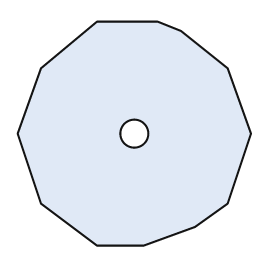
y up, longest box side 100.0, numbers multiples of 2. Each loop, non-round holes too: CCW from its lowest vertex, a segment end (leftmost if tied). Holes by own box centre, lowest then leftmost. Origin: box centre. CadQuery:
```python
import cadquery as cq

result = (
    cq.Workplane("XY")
    .moveTo(-16.0, -48.0)
    .lineTo(4.0, -48.0)
    .lineTo(26.0, -40.0)
    .lineTo(40.0, -30.0)
    .lineTo(50.0, 0.0)
    .lineTo(40.0, 28.0)
    .lineTo(20.0, 44.0)
    .lineTo(10.0, 48.0)
    .lineTo(-16.0, 48.0)
    .lineTo(-40.0, 28.0)
    .lineTo(-50.0, 0.0)
    .lineTo(-40.0, -30.0)
    .close()
    .moveTo(0.0, 0.0)
    .circle(6.0)
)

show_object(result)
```